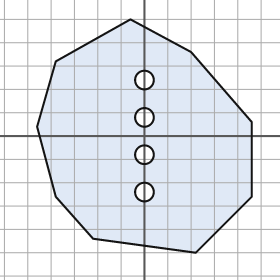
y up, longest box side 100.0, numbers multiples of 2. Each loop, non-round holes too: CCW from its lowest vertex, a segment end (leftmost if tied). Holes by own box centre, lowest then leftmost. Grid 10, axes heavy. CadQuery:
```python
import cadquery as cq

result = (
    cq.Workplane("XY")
    .moveTo(22.0, -50.0)
    .lineTo(46.0, -26.0)
    .lineTo(46.0, 6.0)
    .lineTo(20.0, 36.0)
    .lineTo(-6.0, 50.0)
    .lineTo(-38.0, 32.0)
    .lineTo(-46.0, 4.0)
    .lineTo(-38.0, -26.0)
    .lineTo(-22.0, -44.0)
    .close()
    .moveTo(0.0, -24.0)
    .circle(4.0)
    .moveTo(0.0, -8.0)
    .circle(4.0)
    .moveTo(0.0, 8.0)
    .circle(4.0)
    .moveTo(0.0, 24.0)
    .circle(4.0)
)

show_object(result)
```